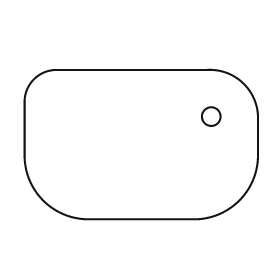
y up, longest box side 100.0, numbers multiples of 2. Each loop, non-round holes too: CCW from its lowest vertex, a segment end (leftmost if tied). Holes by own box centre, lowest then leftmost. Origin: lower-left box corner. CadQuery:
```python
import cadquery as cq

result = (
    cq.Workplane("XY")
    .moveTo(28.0, 0.0)
    .lineTo(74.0, 0.0)
    .threePointArc((92.0, 8.0), (100.0, 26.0))
    .lineTo(100.0, 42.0)
    .threePointArc((94.0, 58.0), (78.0, 64.0))
    .lineTo(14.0, 64.0)
    .threePointArc((4.0, 60.0), (0.0, 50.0))
    .lineTo(0.0, 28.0)
    .threePointArc((8.0, 8.0), (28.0, 0.0))
    .close()
    .moveTo(80.0, 44.0)
    .circle(4.0)
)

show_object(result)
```